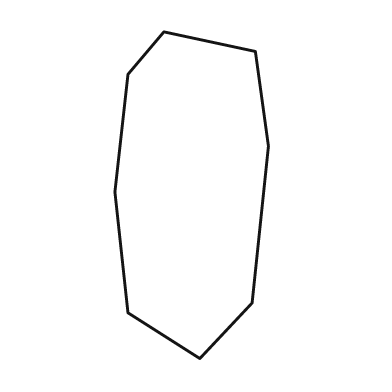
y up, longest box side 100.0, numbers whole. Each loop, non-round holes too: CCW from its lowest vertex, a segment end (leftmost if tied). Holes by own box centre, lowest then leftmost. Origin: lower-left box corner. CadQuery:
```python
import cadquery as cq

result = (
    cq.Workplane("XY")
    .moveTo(26.0, 0.0)
    .lineTo(42.0, 17.0)
    .lineTo(47.0, 65.0)
    .lineTo(43.0, 94.0)
    .lineTo(15.0, 100.0)
    .lineTo(4.0, 87.0)
    .lineTo(0.0, 51.0)
    .lineTo(4.0, 14.0)
    .close()
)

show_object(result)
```